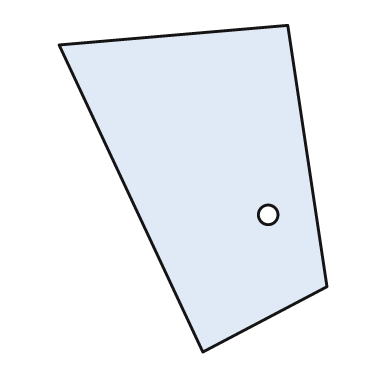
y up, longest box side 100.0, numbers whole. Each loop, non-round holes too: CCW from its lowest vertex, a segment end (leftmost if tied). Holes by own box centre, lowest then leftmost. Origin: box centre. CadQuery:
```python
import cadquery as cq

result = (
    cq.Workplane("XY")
    .moveTo(3.0, -50.0)
    .lineTo(41.0, -30.0)
    .lineTo(29.0, 50.0)
    .lineTo(-41.0, 44.0)
    .close()
    .moveTo(23.0, -8.0)
    .circle(3.0)
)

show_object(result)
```